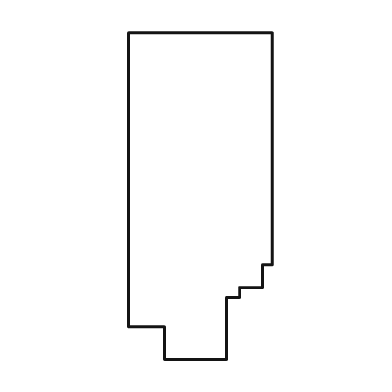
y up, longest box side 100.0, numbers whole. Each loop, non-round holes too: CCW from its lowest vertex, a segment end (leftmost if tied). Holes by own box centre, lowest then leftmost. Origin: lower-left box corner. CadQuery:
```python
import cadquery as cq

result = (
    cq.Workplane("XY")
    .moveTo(11.0, 0.0)
    .lineTo(30.0, 0.0)
    .lineTo(30.0, 19.0)
    .lineTo(34.0, 19.0)
    .lineTo(34.0, 22.0)
    .lineTo(41.0, 22.0)
    .lineTo(41.0, 29.0)
    .lineTo(44.0, 29.0)
    .lineTo(44.0, 100.0)
    .lineTo(0.0, 100.0)
    .lineTo(0.0, 10.0)
    .lineTo(11.0, 10.0)
    .close()
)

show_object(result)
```